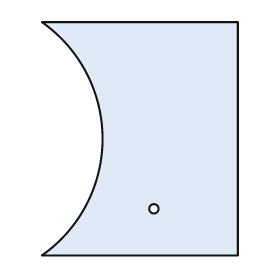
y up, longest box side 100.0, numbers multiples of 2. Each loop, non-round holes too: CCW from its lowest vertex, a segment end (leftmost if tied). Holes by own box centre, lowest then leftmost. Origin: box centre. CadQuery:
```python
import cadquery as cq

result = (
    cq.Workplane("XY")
    .moveTo(-42.0, -50.0)
    .lineTo(42.0, -50.0)
    .lineTo(42.0, 50.0)
    .lineTo(-42.0, 50.0)
    .threePointArc((-16.0, 0.0), (-42.0, -50.0))
    .close()
    .moveTo(6.0, -30.0)
    .circle(2.0)
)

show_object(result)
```